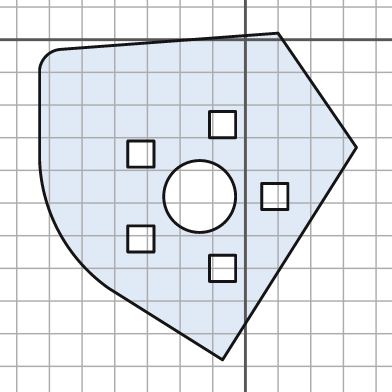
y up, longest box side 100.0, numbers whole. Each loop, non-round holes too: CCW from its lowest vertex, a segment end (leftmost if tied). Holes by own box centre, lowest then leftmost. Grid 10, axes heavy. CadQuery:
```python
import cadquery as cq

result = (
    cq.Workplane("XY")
    .moveTo(-7.0, -98.0)
    .lineTo(34.0, -33.0)
    .lineTo(10.0, 2.0)
    .lineTo(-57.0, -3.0)
    .threePointArc((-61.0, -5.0), (-63.0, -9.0))
    .lineTo(-63.0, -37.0)
    .threePointArc((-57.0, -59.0), (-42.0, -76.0))
    .close()
    .moveTo(-11.0, -74.0)
    .lineTo(-3.0, -74.0)
    .lineTo(-3.0, -66.0)
    .lineTo(-11.0, -66.0)
    .close()
    .moveTo(-36.0, -65.0)
    .lineTo(-28.0, -65.0)
    .lineTo(-28.0, -57.0)
    .lineTo(-36.0, -57.0)
    .close()
    .moveTo(-14.0, -48.0)
    .circle(11.0)
    .moveTo(5.0, -52.0)
    .lineTo(13.0, -52.0)
    .lineTo(13.0, -44.0)
    .lineTo(5.0, -44.0)
    .close()
    .moveTo(-36.0, -39.0)
    .lineTo(-28.0, -39.0)
    .lineTo(-28.0, -31.0)
    .lineTo(-36.0, -31.0)
    .close()
    .moveTo(-11.0, -30.0)
    .lineTo(-3.0, -30.0)
    .lineTo(-3.0, -22.0)
    .lineTo(-11.0, -22.0)
    .close()
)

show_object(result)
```